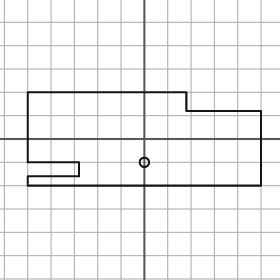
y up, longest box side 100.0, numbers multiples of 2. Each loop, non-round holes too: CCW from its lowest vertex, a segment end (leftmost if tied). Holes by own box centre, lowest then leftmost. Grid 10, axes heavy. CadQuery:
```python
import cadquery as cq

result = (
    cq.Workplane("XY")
    .moveTo(-50.0, -20.0)
    .lineTo(50.0, -20.0)
    .lineTo(50.0, 12.0)
    .lineTo(18.0, 12.0)
    .lineTo(18.0, 20.0)
    .lineTo(-50.0, 20.0)
    .lineTo(-50.0, -10.0)
    .lineTo(-28.0, -10.0)
    .lineTo(-28.0, -16.0)
    .lineTo(-50.0, -16.0)
    .close()
    .moveTo(0.0, -10.0)
    .circle(2.0)
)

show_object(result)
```